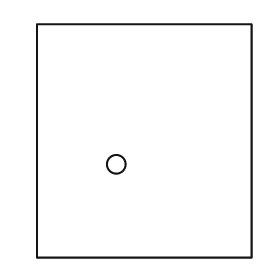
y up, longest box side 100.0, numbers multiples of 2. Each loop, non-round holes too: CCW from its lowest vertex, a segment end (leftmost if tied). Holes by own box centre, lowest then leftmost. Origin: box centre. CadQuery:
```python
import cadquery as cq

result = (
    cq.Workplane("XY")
    .moveTo(-46.0, -50.0)
    .lineTo(46.0, -50.0)
    .lineTo(46.0, 50.0)
    .lineTo(-46.0, 50.0)
    .close()
    .moveTo(-12.0, -10.0)
    .circle(4.0)
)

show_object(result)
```